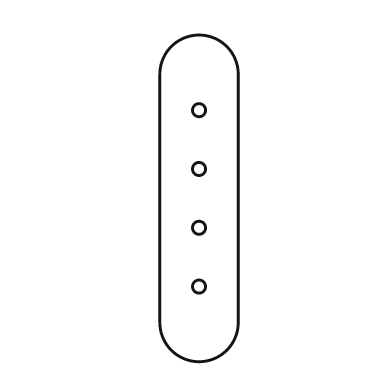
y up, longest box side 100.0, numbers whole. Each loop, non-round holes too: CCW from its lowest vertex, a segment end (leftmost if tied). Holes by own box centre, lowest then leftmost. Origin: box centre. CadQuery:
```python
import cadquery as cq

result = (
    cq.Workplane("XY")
    .moveTo(-12.0, -38.0)
    .threePointArc((0.0, -50.0), (12.0, -38.0))
    .lineTo(12.0, 38.0)
    .threePointArc((0.0, 50.0), (-12.0, 38.0))
    .close()
    .moveTo(0.0, -27.0)
    .circle(2.0)
    .moveTo(0.0, -9.0)
    .circle(2.0)
    .moveTo(0.0, 9.0)
    .circle(2.0)
    .moveTo(0.0, 27.0)
    .circle(2.0)
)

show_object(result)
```